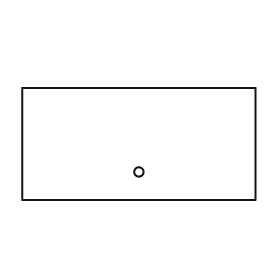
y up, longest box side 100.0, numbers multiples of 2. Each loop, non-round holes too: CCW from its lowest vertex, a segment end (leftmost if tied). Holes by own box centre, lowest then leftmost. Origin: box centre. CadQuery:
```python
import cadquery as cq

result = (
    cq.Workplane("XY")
    .moveTo(-50.0, -24.0)
    .lineTo(50.0, -24.0)
    .lineTo(50.0, 24.0)
    .lineTo(-50.0, 24.0)
    .close()
    .moveTo(0.0, -12.0)
    .circle(2.0)
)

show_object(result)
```